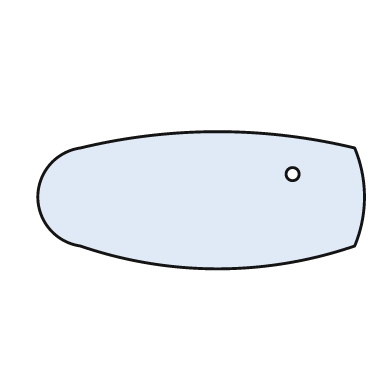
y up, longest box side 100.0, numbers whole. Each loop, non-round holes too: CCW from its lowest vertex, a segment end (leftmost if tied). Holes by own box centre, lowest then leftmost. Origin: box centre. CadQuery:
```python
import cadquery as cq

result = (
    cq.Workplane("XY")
    .moveTo(-37.0, -14.0)
    .threePointArc((5.0, -21.0), (47.0, -14.0))
    .threePointArc((50.0, 1.0), (47.0, 16.0))
    .threePointArc((5.0, 21.0), (-37.0, 16.0))
    .threePointArc((-50.0, 1.0), (-37.0, -14.0))
    .close()
    .moveTo(28.0, 8.0)
    .circle(2.0)
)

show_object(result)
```